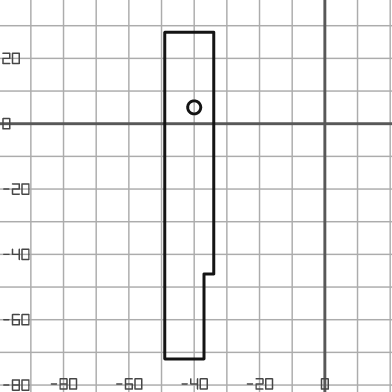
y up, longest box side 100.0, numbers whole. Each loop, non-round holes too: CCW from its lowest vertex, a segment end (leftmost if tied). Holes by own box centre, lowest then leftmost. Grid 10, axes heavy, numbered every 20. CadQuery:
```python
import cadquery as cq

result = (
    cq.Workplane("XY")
    .moveTo(-49.0, -72.0)
    .lineTo(-37.0, -72.0)
    .lineTo(-37.0, -46.0)
    .lineTo(-34.0, -46.0)
    .lineTo(-34.0, 28.0)
    .lineTo(-49.0, 28.0)
    .close()
    .moveTo(-40.0, 5.0)
    .circle(2.0)
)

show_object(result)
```